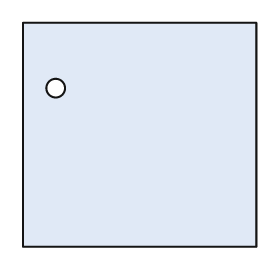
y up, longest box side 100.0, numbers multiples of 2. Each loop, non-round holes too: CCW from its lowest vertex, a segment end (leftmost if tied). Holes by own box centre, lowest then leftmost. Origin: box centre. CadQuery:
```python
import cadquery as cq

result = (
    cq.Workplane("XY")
    .moveTo(-50.0, -48.0)
    .lineTo(50.0, -48.0)
    .lineTo(50.0, 48.0)
    .lineTo(-50.0, 48.0)
    .close()
    .moveTo(-36.0, 20.0)
    .circle(4.0)
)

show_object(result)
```